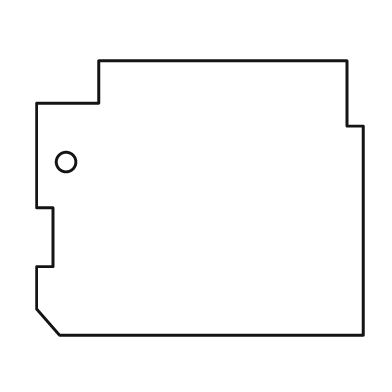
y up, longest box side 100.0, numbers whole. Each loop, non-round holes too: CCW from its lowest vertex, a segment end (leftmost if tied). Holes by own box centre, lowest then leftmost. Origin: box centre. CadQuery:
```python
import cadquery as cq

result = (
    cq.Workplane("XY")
    .moveTo(-43.0, -42.0)
    .lineTo(50.0, -42.0)
    .lineTo(50.0, 22.0)
    .lineTo(45.0, 22.0)
    .lineTo(45.0, 42.0)
    .lineTo(-31.0, 42.0)
    .lineTo(-31.0, 29.0)
    .lineTo(-50.0, 29.0)
    .lineTo(-50.0, -3.0)
    .lineTo(-45.0, -3.0)
    .lineTo(-45.0, -21.0)
    .lineTo(-50.0, -21.0)
    .lineTo(-50.0, -34.0)
    .close()
    .moveTo(-41.0, 11.0)
    .circle(3.0)
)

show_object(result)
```